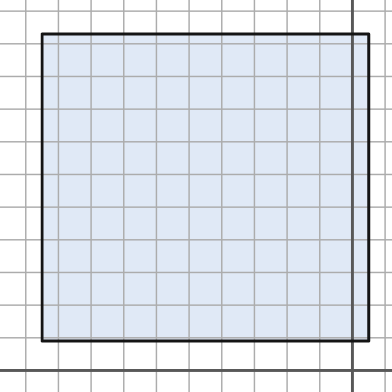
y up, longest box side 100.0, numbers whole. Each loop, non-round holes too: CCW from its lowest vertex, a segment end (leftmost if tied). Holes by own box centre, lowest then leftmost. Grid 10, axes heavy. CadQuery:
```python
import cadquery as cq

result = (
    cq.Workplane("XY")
    .moveTo(-95.0, 9.0)
    .lineTo(5.0, 9.0)
    .lineTo(5.0, 103.0)
    .lineTo(-95.0, 103.0)
    .close()
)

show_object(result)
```